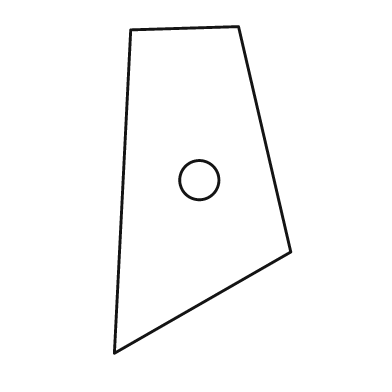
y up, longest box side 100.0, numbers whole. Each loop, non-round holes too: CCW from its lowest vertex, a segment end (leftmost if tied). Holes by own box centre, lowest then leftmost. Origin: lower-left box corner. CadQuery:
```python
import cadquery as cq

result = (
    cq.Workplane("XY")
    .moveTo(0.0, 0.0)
    .lineTo(54.0, 31.0)
    .lineTo(38.0, 100.0)
    .lineTo(5.0, 99.0)
    .close()
    .moveTo(26.0, 53.0)
    .circle(6.0)
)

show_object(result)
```